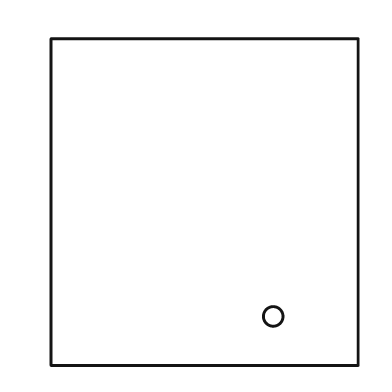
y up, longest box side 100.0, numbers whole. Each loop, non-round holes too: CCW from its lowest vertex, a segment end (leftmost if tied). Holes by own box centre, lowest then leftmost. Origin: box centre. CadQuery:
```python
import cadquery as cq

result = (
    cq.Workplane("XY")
    .moveTo(-47.0, -50.0)
    .lineTo(47.0, -50.0)
    .lineTo(47.0, 50.0)
    .lineTo(-47.0, 50.0)
    .close()
    .moveTo(21.0, -35.0)
    .circle(3.0)
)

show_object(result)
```